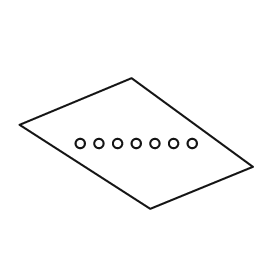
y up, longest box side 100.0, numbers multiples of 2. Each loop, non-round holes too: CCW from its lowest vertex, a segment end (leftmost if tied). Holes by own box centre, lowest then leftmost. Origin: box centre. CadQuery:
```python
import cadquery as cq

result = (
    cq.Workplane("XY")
    .moveTo(6.0, -28.0)
    .lineTo(50.0, -10.0)
    .lineTo(-2.0, 28.0)
    .lineTo(-50.0, 8.0)
    .close()
    .moveTo(-24.0, 0.0)
    .circle(2.0)
    .moveTo(-16.0, 0.0)
    .circle(2.0)
    .moveTo(-8.0, 0.0)
    .circle(2.0)
    .moveTo(0.0, 0.0)
    .circle(2.0)
    .moveTo(8.0, 0.0)
    .circle(2.0)
    .moveTo(16.0, 0.0)
    .circle(2.0)
    .moveTo(24.0, 0.0)
    .circle(2.0)
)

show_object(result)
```